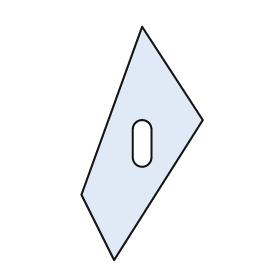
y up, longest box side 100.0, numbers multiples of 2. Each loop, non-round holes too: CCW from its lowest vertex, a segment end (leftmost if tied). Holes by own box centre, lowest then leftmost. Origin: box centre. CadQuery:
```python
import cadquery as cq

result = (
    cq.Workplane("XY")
    .moveTo(-12.0, -50.0)
    .lineTo(26.0, 10.0)
    .lineTo(0.0, 50.0)
    .lineTo(-26.0, -22.0)
    .close()
    .moveTo(-4.0, -6.0)
    .threePointArc((0.0, -10.0), (4.0, -6.0))
    .lineTo(4.0, 6.0)
    .threePointArc((0.0, 10.0), (-4.0, 6.0))
    .close()
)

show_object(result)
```